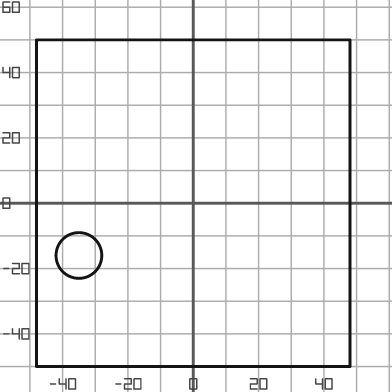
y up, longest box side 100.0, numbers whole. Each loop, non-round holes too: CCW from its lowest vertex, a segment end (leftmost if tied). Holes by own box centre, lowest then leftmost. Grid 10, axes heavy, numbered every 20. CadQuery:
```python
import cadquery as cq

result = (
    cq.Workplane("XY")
    .moveTo(-48.0, -50.0)
    .lineTo(48.0, -50.0)
    .lineTo(48.0, 50.0)
    .lineTo(-48.0, 50.0)
    .close()
    .moveTo(-35.0, -16.0)
    .circle(7.0)
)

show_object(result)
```